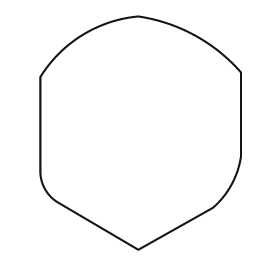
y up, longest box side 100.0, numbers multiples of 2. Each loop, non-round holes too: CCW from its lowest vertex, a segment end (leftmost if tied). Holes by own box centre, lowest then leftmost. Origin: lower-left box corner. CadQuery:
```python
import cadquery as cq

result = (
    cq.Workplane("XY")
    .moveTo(42.0, 0.0)
    .lineTo(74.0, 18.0)
    .threePointArc((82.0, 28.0), (86.0, 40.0))
    .lineTo(86.0, 76.0)
    .threePointArc((66.0, 92.0), (42.0, 100.0))
    .threePointArc((18.0, 92.0), (0.0, 74.0))
    .lineTo(0.0, 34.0)
    .threePointArc((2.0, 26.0), (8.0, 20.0))
    .close()
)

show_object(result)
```